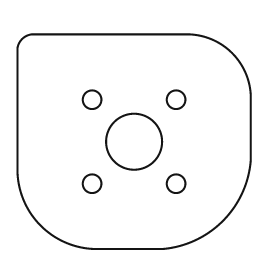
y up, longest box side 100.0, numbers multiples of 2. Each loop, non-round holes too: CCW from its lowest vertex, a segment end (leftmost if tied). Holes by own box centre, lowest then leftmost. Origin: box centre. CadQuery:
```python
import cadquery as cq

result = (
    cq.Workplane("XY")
    .moveTo(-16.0, -46.0)
    .lineTo(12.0, -46.0)
    .threePointArc((38.0, -34.0), (50.0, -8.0))
    .lineTo(50.0, 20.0)
    .threePointArc((42.0, 38.0), (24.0, 46.0))
    .lineTo(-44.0, 46.0)
    .threePointArc((-48.0, 44.0), (-50.0, 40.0))
    .lineTo(-50.0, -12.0)
    .threePointArc((-40.0, -36.0), (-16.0, -46.0))
    .close()
    .moveTo(-18.0, -18.0)
    .circle(4.0)
    .moveTo(18.0, -18.0)
    .circle(4.0)
    .moveTo(0.0, 0.0)
    .circle(12.0)
    .moveTo(-18.0, 18.0)
    .circle(4.0)
    .moveTo(18.0, 18.0)
    .circle(4.0)
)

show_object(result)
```